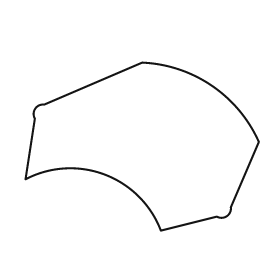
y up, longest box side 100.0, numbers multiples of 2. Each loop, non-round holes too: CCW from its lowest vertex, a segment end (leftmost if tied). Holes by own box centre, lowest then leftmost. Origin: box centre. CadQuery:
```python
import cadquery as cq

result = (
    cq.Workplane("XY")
    .moveTo(8.0, -36.0)
    .lineTo(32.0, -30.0)
    .threePointArc((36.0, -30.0), (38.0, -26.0))
    .lineTo(50.0, 2.0)
    .threePointArc((30.0, 26.0), (0.0, 36.0))
    .lineTo(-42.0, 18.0)
    .threePointArc((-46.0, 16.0), (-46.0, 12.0))
    .lineTo(-50.0, -14.0)
    .threePointArc((-16.0, -12.0), (8.0, -36.0))
    .close()
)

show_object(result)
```